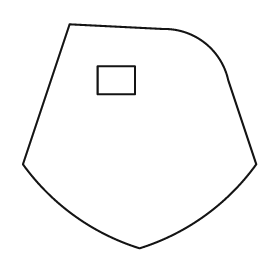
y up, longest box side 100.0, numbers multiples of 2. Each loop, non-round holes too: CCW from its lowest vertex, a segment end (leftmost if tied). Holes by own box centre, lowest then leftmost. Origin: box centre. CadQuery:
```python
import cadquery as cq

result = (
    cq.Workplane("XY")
    .moveTo(0.0, -48.0)
    .threePointArc((28.0, -34.0), (50.0, -12.0))
    .lineTo(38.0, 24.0)
    .threePointArc((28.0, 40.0), (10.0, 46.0))
    .lineTo(-30.0, 48.0)
    .lineTo(-50.0, -12.0)
    .threePointArc((-28.0, -34.0), (0.0, -48.0))
    .close()
    .moveTo(-18.0, 18.0)
    .lineTo(-2.0, 18.0)
    .lineTo(-2.0, 30.0)
    .lineTo(-18.0, 30.0)
    .close()
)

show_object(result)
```